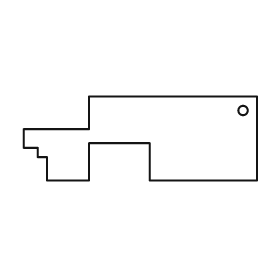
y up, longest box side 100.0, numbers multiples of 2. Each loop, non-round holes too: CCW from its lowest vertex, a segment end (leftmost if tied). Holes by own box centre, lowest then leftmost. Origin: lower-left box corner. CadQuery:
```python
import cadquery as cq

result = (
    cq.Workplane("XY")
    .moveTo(10.0, 0.0)
    .lineTo(28.0, 0.0)
    .lineTo(28.0, 16.0)
    .lineTo(54.0, 16.0)
    .lineTo(54.0, 0.0)
    .lineTo(100.0, 0.0)
    .lineTo(100.0, 36.0)
    .lineTo(28.0, 36.0)
    .lineTo(28.0, 22.0)
    .lineTo(0.0, 22.0)
    .lineTo(0.0, 14.0)
    .lineTo(6.0, 14.0)
    .lineTo(6.0, 10.0)
    .lineTo(10.0, 10.0)
    .close()
    .moveTo(94.0, 30.0)
    .circle(2.0)
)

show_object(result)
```